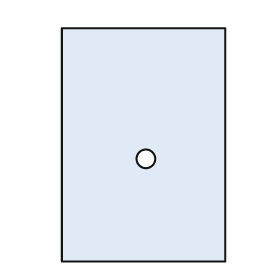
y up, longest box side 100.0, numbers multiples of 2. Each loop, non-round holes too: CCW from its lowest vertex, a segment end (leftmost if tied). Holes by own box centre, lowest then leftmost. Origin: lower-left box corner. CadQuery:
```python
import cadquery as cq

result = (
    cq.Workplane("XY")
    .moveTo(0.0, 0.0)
    .lineTo(70.0, 0.0)
    .lineTo(70.0, 100.0)
    .lineTo(0.0, 100.0)
    .close()
    .moveTo(36.0, 44.0)
    .circle(4.0)
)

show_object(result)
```